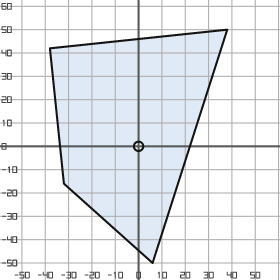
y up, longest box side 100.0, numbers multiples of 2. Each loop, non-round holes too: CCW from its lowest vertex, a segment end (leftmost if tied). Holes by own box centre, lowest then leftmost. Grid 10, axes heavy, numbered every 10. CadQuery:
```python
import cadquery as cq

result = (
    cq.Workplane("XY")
    .moveTo(6.0, -50.0)
    .lineTo(38.0, 50.0)
    .lineTo(-38.0, 42.0)
    .lineTo(-32.0, -16.0)
    .close()
    .moveTo(0.0, 0.0)
    .circle(2.0)
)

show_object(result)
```